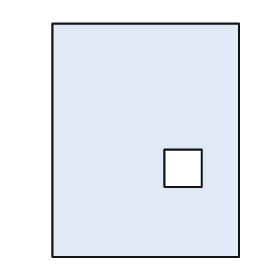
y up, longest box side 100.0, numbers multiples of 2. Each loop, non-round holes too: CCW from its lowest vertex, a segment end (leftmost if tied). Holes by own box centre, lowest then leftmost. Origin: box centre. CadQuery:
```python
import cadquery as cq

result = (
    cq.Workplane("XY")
    .moveTo(-40.0, -50.0)
    .lineTo(40.0, -50.0)
    .lineTo(40.0, 50.0)
    .lineTo(-40.0, 50.0)
    .close()
    .moveTo(8.0, -20.0)
    .lineTo(24.0, -20.0)
    .lineTo(24.0, -4.0)
    .lineTo(8.0, -4.0)
    .close()
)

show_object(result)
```